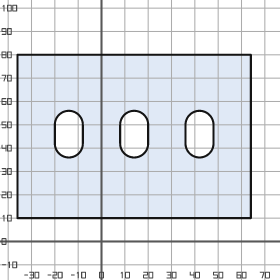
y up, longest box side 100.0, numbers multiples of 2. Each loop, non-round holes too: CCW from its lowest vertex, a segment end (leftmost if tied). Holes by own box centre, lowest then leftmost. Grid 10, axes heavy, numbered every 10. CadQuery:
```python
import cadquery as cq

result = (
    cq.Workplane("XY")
    .moveTo(-36.0, 10.0)
    .lineTo(64.0, 10.0)
    .lineTo(64.0, 80.0)
    .lineTo(-36.0, 80.0)
    .close()
    .moveTo(-20.0, 42.0)
    .threePointArc((-14.0, 36.0), (-8.0, 42.0))
    .lineTo(-8.0, 50.0)
    .threePointArc((-14.0, 56.0), (-20.0, 50.0))
    .close()
    .moveTo(8.0, 42.0)
    .threePointArc((14.0, 36.0), (20.0, 42.0))
    .lineTo(20.0, 50.0)
    .threePointArc((14.0, 56.0), (8.0, 50.0))
    .close()
    .moveTo(36.0, 42.0)
    .threePointArc((42.0, 36.0), (48.0, 42.0))
    .lineTo(48.0, 50.0)
    .threePointArc((42.0, 56.0), (36.0, 50.0))
    .close()
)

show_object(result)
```